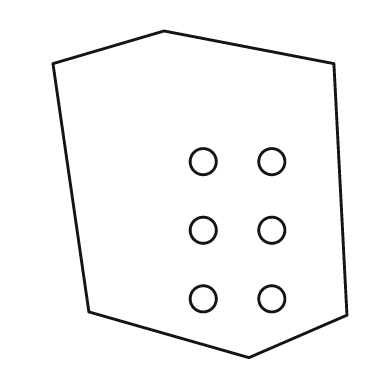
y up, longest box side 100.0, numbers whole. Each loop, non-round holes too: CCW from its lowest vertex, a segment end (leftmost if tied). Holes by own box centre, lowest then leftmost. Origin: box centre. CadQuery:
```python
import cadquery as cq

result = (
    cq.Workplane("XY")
    .moveTo(15.0, -50.0)
    .lineTo(45.0, -37.0)
    .lineTo(41.0, 40.0)
    .lineTo(-11.0, 50.0)
    .lineTo(-45.0, 40.0)
    .lineTo(-34.0, -36.0)
    .close()
    .moveTo(1.0, -32.0)
    .circle(4.0)
    .moveTo(22.0, -32.0)
    .circle(4.0)
    .moveTo(1.0, -11.0)
    .circle(4.0)
    .moveTo(22.0, -11.0)
    .circle(4.0)
    .moveTo(1.0, 10.0)
    .circle(4.0)
    .moveTo(22.0, 10.0)
    .circle(4.0)
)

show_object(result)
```